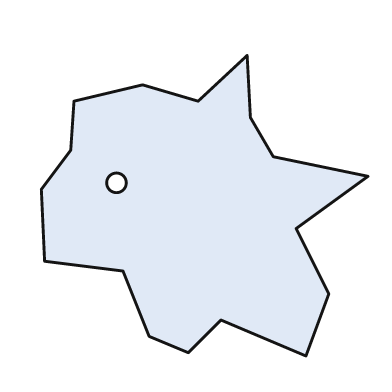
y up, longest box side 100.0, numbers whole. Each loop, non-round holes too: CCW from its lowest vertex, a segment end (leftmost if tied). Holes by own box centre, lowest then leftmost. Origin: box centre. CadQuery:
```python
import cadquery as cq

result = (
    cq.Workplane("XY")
    .moveTo(31.0, -46.0)
    .lineTo(38.0, -27.0)
    .lineTo(28.0, -7.0)
    .lineTo(50.0, 9.0)
    .lineTo(21.0, 15.0)
    .lineTo(14.0, 27.0)
    .lineTo(13.0, 46.0)
    .lineTo(-2.0, 32.0)
    .lineTo(-19.0, 37.0)
    .lineTo(-40.0, 32.0)
    .lineTo(-41.0, 17.0)
    .lineTo(-50.0, 5.0)
    .lineTo(-49.0, -17.0)
    .lineTo(-25.0, -20.0)
    .lineTo(-17.0, -40.0)
    .lineTo(-5.0, -45.0)
    .lineTo(5.0, -35.0)
    .close()
    .moveTo(-27.0, 7.0)
    .circle(3.0)
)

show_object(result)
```